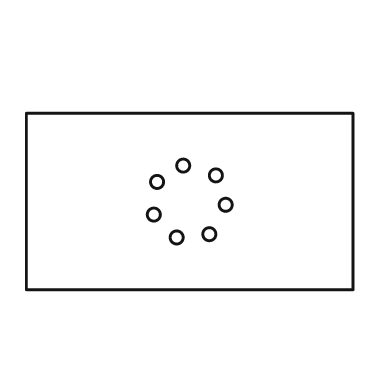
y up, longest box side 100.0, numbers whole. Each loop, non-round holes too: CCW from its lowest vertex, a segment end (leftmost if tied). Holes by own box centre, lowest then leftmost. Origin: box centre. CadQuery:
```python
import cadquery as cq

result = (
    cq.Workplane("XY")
    .moveTo(-50.0, -27.0)
    .lineTo(50.0, -27.0)
    .lineTo(50.0, 27.0)
    .lineTo(-50.0, 27.0)
    .close()
    .moveTo(-4.0, -11.0)
    .circle(2.0)
    .moveTo(6.0, -10.0)
    .circle(2.0)
    .moveTo(-11.0, -4.0)
    .circle(2.0)
    .moveTo(11.0, -1.0)
    .circle(2.0)
    .moveTo(-10.0, 6.0)
    .circle(2.0)
    .moveTo(8.0, 8.0)
    .circle(2.0)
    .moveTo(-2.0, 11.0)
    .circle(2.0)
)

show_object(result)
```